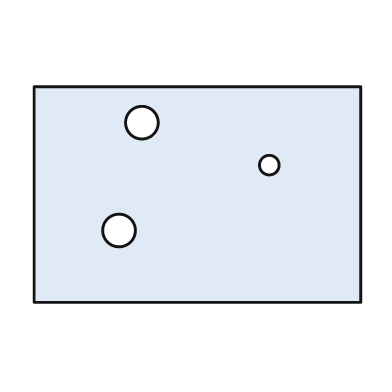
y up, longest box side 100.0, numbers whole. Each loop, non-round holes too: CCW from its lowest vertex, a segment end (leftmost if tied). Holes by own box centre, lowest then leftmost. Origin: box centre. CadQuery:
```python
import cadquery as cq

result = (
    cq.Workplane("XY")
    .moveTo(-50.0, -33.0)
    .lineTo(50.0, -33.0)
    .lineTo(50.0, 33.0)
    .lineTo(-50.0, 33.0)
    .close()
    .moveTo(-24.0, -11.0)
    .circle(5.0)
    .moveTo(22.0, 9.0)
    .circle(3.0)
    .moveTo(-17.0, 22.0)
    .circle(5.0)
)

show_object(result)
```